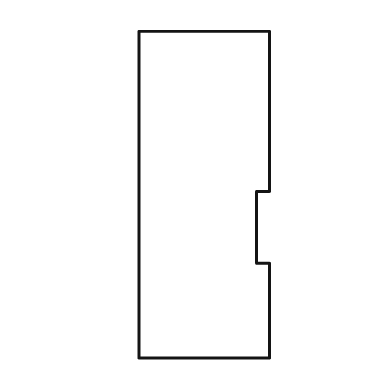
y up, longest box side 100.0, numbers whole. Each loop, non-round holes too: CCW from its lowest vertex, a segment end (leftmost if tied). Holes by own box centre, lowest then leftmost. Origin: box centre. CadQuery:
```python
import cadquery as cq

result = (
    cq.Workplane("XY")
    .moveTo(-20.0, -50.0)
    .lineTo(20.0, -50.0)
    .lineTo(20.0, -21.0)
    .lineTo(16.0, -21.0)
    .lineTo(16.0, 1.0)
    .lineTo(20.0, 1.0)
    .lineTo(20.0, 50.0)
    .lineTo(-20.0, 50.0)
    .close()
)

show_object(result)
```